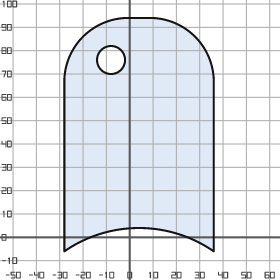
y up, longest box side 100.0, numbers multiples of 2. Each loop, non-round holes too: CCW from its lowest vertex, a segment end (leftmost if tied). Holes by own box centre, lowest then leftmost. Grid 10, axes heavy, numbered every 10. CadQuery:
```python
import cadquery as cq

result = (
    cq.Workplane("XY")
    .moveTo(-28.0, -6.0)
    .threePointArc((4.0, 4.0), (36.0, -6.0))
    .lineTo(36.0, 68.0)
    .threePointArc((28.0, 86.0), (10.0, 94.0))
    .lineTo(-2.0, 94.0)
    .threePointArc((-20.0, 86.0), (-28.0, 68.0))
    .close()
    .moveTo(-8.0, 76.0)
    .circle(6.0)
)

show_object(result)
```